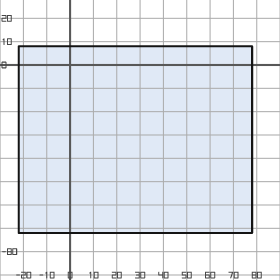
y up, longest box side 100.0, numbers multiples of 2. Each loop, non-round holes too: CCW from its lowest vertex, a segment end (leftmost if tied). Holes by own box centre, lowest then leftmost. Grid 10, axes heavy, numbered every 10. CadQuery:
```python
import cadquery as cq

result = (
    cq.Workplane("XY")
    .moveTo(-22.0, -72.0)
    .lineTo(78.0, -72.0)
    .lineTo(78.0, 8.0)
    .lineTo(-22.0, 8.0)
    .close()
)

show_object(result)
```